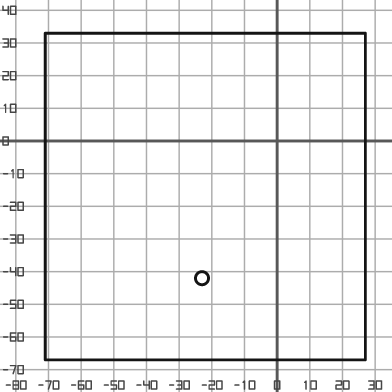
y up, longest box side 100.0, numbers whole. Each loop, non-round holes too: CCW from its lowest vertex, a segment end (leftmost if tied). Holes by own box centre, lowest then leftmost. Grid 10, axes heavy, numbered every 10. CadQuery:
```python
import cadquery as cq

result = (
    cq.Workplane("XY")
    .moveTo(-71.0, -67.0)
    .lineTo(27.0, -67.0)
    .lineTo(27.0, 33.0)
    .lineTo(-71.0, 33.0)
    .close()
    .moveTo(-23.0, -42.0)
    .circle(2.0)
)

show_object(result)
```